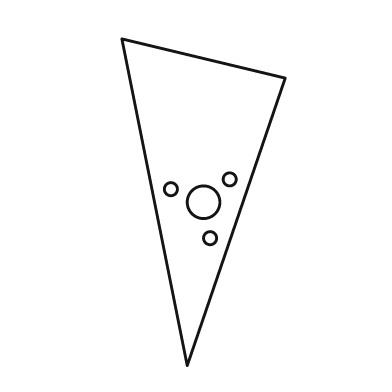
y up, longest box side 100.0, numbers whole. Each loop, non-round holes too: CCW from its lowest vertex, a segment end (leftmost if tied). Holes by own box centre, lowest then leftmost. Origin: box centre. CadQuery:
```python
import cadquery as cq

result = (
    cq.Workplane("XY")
    .moveTo(-5.0, -50.0)
    .lineTo(25.0, 38.0)
    .lineTo(-25.0, 50.0)
    .close()
    .moveTo(2.0, -11.0)
    .circle(2.0)
    .moveTo(0.0, 0.0)
    .circle(5.0)
    .moveTo(-10.0, 4.0)
    .circle(2.0)
    .moveTo(8.0, 7.0)
    .circle(2.0)
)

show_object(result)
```